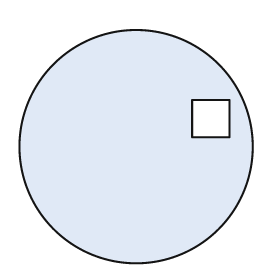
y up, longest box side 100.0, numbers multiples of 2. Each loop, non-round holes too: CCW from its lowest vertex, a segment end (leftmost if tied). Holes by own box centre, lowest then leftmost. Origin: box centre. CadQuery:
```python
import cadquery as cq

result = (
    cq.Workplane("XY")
    .moveTo(0.0, 0.0)
    .circle(50.0)
    .moveTo(24.0, 4.0)
    .lineTo(40.0, 4.0)
    .lineTo(40.0, 20.0)
    .lineTo(24.0, 20.0)
    .close()
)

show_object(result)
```